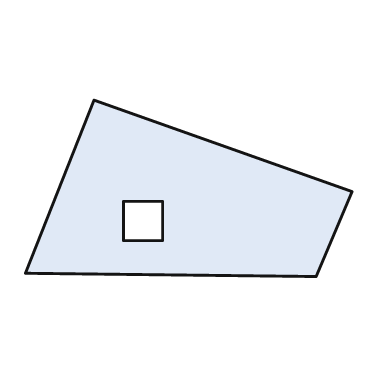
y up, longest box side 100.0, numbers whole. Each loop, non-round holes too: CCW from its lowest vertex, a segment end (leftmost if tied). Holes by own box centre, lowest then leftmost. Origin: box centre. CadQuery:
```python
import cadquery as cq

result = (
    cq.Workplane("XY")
    .moveTo(39.0, -27.0)
    .lineTo(50.0, -1.0)
    .lineTo(-29.0, 27.0)
    .lineTo(-50.0, -26.0)
    .close()
    .moveTo(-20.0, -16.0)
    .lineTo(-8.0, -16.0)
    .lineTo(-8.0, -4.0)
    .lineTo(-20.0, -4.0)
    .close()
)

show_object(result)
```